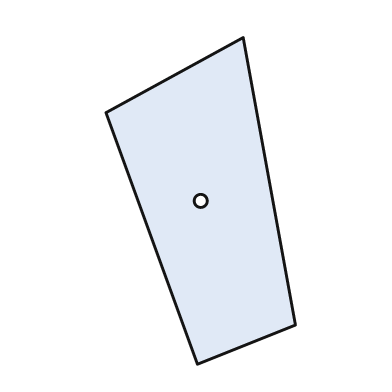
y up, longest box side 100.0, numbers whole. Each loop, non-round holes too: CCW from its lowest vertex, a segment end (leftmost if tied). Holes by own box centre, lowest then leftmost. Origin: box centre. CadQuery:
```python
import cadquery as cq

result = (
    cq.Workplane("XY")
    .moveTo(-1.0, -50.0)
    .lineTo(29.0, -38.0)
    .lineTo(13.0, 50.0)
    .lineTo(-29.0, 27.0)
    .close()
    .moveTo(0.0, 0.0)
    .circle(2.0)
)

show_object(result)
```